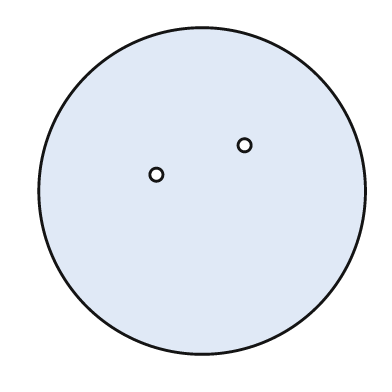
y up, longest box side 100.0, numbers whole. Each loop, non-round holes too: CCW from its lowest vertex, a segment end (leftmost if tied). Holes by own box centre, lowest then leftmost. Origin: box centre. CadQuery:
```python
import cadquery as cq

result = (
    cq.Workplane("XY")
    .moveTo(0.0, 0.0)
    .circle(50.0)
    .moveTo(-14.0, 5.0)
    .circle(2.0)
    .moveTo(13.0, 14.0)
    .circle(2.0)
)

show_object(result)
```